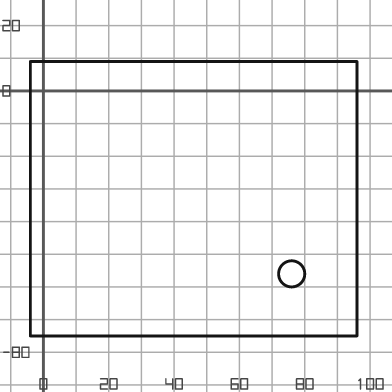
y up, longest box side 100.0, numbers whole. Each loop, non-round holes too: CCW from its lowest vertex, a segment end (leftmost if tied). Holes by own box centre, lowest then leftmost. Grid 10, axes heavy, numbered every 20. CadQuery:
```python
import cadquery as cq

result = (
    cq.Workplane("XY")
    .moveTo(-4.0, -75.0)
    .lineTo(96.0, -75.0)
    .lineTo(96.0, 9.0)
    .lineTo(-4.0, 9.0)
    .close()
    .moveTo(76.0, -56.0)
    .circle(4.0)
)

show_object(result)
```